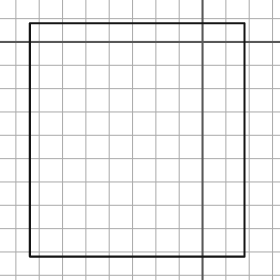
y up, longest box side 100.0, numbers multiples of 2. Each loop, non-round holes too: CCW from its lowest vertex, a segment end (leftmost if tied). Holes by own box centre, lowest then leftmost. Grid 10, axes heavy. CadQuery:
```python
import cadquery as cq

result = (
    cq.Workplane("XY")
    .moveTo(-74.0, -92.0)
    .lineTo(18.0, -92.0)
    .lineTo(18.0, 8.0)
    .lineTo(-74.0, 8.0)
    .close()
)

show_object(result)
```